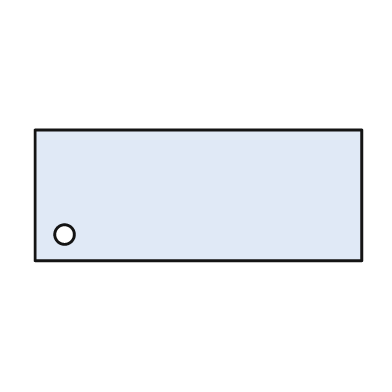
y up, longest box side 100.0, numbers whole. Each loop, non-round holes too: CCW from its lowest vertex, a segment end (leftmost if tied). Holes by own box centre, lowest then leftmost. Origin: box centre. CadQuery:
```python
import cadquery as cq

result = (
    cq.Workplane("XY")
    .moveTo(-50.0, -20.0)
    .lineTo(50.0, -20.0)
    .lineTo(50.0, 20.0)
    .lineTo(-50.0, 20.0)
    .close()
    .moveTo(-41.0, -12.0)
    .circle(3.0)
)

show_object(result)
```